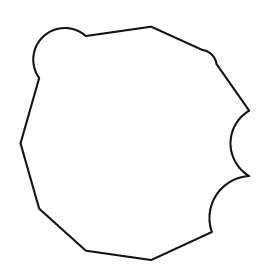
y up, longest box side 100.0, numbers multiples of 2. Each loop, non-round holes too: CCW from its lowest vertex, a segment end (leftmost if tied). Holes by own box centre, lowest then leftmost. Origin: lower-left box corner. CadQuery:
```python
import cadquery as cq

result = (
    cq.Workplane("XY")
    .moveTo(56.0, 0.0)
    .lineTo(82.0, 12.0)
    .threePointArc((84.0, 28.0), (98.0, 36.0))
    .threePointArc((90.0, 50.0), (98.0, 64.0))
    .lineTo(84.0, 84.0)
    .threePointArc((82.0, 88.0), (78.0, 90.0))
    .lineTo(56.0, 100.0)
    .lineTo(28.0, 96.0)
    .threePointArc((10.0, 96.0), (8.0, 78.0))
    .lineTo(0.0, 50.0)
    .lineTo(8.0, 22.0)
    .lineTo(28.0, 4.0)
    .close()
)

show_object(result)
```